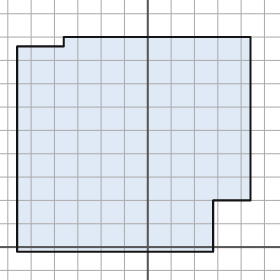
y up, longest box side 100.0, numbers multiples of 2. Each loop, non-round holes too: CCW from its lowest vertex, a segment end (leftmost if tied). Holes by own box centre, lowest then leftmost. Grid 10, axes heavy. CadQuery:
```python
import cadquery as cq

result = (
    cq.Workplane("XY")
    .moveTo(-56.0, -2.0)
    .lineTo(28.0, -2.0)
    .lineTo(28.0, 20.0)
    .lineTo(44.0, 20.0)
    .lineTo(44.0, 90.0)
    .lineTo(-36.0, 90.0)
    .lineTo(-36.0, 86.0)
    .lineTo(-56.0, 86.0)
    .close()
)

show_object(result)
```